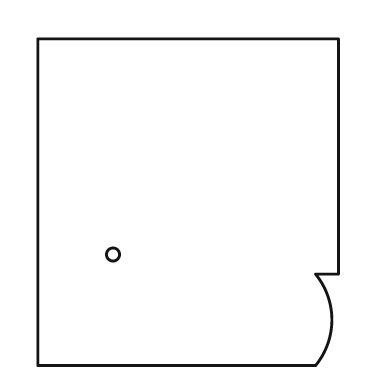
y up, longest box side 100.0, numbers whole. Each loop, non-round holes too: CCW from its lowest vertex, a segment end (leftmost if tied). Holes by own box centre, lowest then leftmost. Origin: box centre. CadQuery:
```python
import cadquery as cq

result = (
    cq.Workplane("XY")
    .moveTo(-46.0, -50.0)
    .lineTo(39.0, -50.0)
    .threePointArc((44.0, -36.0), (39.0, -22.0))
    .lineTo(46.0, -22.0)
    .lineTo(46.0, 50.0)
    .lineTo(-46.0, 50.0)
    .close()
    .moveTo(-23.0, -16.0)
    .circle(2.0)
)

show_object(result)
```